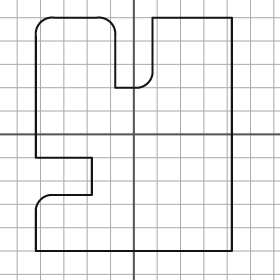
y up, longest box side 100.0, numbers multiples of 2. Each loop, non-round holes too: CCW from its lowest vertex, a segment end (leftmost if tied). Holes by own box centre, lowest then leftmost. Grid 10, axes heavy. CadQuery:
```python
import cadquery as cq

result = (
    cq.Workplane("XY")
    .moveTo(-42.0, -50.0)
    .lineTo(42.0, -50.0)
    .lineTo(42.0, 50.0)
    .lineTo(8.0, 50.0)
    .lineTo(8.0, 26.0)
    .threePointArc((6.0, 22.0), (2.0, 20.0))
    .lineTo(-8.0, 20.0)
    .lineTo(-8.0, 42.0)
    .threePointArc((-10.0, 48.0), (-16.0, 50.0))
    .lineTo(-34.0, 50.0)
    .threePointArc((-40.0, 48.0), (-42.0, 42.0))
    .lineTo(-42.0, -10.0)
    .lineTo(-18.0, -10.0)
    .lineTo(-18.0, -26.0)
    .lineTo(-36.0, -26.0)
    .threePointArc((-40.0, -28.0), (-42.0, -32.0))
    .close()
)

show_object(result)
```